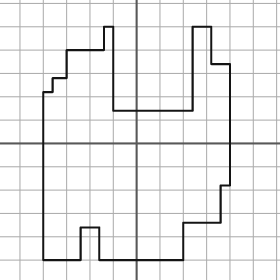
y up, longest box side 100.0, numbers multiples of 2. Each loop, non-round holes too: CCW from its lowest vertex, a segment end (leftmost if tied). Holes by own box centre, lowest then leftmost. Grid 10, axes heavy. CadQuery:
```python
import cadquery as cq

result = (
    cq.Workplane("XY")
    .moveTo(-40.0, -50.0)
    .lineTo(-24.0, -50.0)
    .lineTo(-24.0, -36.0)
    .lineTo(-16.0, -36.0)
    .lineTo(-16.0, -50.0)
    .lineTo(20.0, -50.0)
    .lineTo(20.0, -34.0)
    .lineTo(36.0, -34.0)
    .lineTo(36.0, -18.0)
    .lineTo(40.0, -18.0)
    .lineTo(40.0, 34.0)
    .lineTo(32.0, 34.0)
    .lineTo(32.0, 50.0)
    .lineTo(24.0, 50.0)
    .lineTo(24.0, 14.0)
    .lineTo(-10.0, 14.0)
    .lineTo(-10.0, 50.0)
    .lineTo(-14.0, 50.0)
    .lineTo(-14.0, 40.0)
    .lineTo(-30.0, 40.0)
    .lineTo(-30.0, 28.0)
    .lineTo(-36.0, 28.0)
    .lineTo(-36.0, 22.0)
    .lineTo(-40.0, 22.0)
    .close()
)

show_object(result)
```